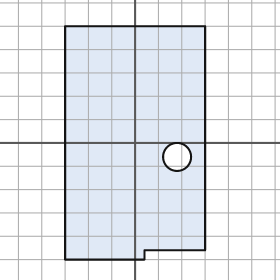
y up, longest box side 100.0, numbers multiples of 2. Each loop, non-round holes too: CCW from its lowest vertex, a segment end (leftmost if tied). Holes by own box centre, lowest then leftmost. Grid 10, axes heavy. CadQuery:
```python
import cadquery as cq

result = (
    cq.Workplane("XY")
    .moveTo(-30.0, -50.0)
    .lineTo(4.0, -50.0)
    .lineTo(4.0, -46.0)
    .lineTo(30.0, -46.0)
    .lineTo(30.0, 50.0)
    .lineTo(-30.0, 50.0)
    .close()
    .moveTo(18.0, -6.0)
    .circle(6.0)
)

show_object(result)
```